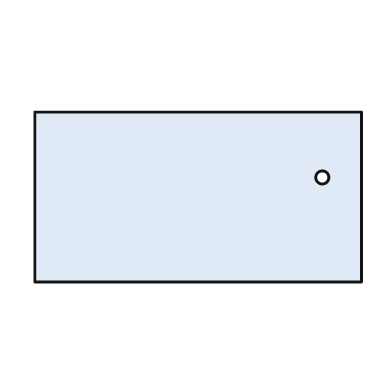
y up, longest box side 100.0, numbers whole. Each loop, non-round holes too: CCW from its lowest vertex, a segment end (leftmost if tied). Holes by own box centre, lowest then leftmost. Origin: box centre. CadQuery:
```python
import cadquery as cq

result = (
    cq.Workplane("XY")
    .moveTo(-50.0, -26.0)
    .lineTo(50.0, -26.0)
    .lineTo(50.0, 26.0)
    .lineTo(-50.0, 26.0)
    .close()
    .moveTo(38.0, 6.0)
    .circle(2.0)
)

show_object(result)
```